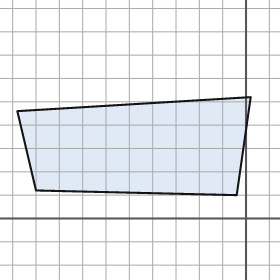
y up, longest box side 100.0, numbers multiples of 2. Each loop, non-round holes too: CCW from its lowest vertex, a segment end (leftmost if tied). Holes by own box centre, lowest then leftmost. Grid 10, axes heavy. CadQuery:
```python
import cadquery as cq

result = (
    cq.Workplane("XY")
    .moveTo(-4.0, 10.0)
    .lineTo(2.0, 52.0)
    .lineTo(-98.0, 46.0)
    .lineTo(-90.0, 12.0)
    .close()
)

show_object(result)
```